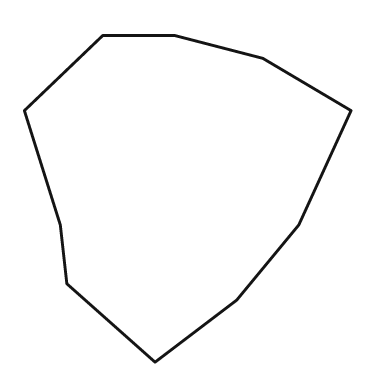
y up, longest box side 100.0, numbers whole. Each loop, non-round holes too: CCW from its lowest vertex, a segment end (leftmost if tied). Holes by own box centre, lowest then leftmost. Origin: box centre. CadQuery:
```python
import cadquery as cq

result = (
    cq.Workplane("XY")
    .moveTo(-10.0, -50.0)
    .lineTo(15.0, -31.0)
    .lineTo(34.0, -8.0)
    .lineTo(50.0, 27.0)
    .lineTo(23.0, 43.0)
    .lineTo(-4.0, 50.0)
    .lineTo(-26.0, 50.0)
    .lineTo(-50.0, 27.0)
    .lineTo(-39.0, -8.0)
    .lineTo(-37.0, -26.0)
    .close()
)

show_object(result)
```